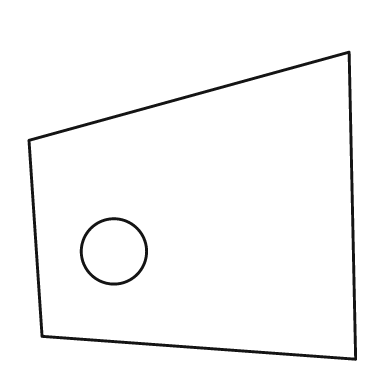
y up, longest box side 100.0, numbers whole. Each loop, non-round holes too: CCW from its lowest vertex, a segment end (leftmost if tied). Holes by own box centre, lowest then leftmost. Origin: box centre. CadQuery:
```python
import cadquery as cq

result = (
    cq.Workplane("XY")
    .moveTo(50.0, -47.0)
    .lineTo(48.0, 47.0)
    .lineTo(-50.0, 20.0)
    .lineTo(-46.0, -40.0)
    .close()
    .moveTo(-24.0, -14.0)
    .circle(10.0)
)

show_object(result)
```